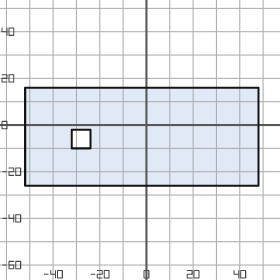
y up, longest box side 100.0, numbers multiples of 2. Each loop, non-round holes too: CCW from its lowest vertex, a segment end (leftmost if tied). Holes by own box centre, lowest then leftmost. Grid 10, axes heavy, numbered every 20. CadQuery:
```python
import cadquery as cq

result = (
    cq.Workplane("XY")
    .moveTo(-52.0, -26.0)
    .lineTo(48.0, -26.0)
    .lineTo(48.0, 16.0)
    .lineTo(-52.0, 16.0)
    .close()
    .moveTo(-32.0, -10.0)
    .lineTo(-24.0, -10.0)
    .lineTo(-24.0, -2.0)
    .lineTo(-32.0, -2.0)
    .close()
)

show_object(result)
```